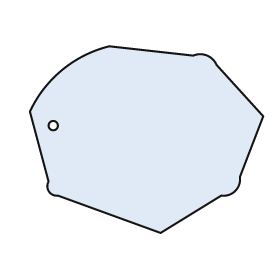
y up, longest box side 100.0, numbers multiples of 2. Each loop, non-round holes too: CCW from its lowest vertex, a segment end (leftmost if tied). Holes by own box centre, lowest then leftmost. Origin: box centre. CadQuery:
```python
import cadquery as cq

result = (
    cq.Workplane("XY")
    .moveTo(6.0, -40.0)
    .lineTo(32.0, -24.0)
    .threePointArc((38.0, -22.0), (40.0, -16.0))
    .lineTo(50.0, 10.0)
    .lineTo(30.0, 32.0)
    .threePointArc((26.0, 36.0), (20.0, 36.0))
    .lineTo(-16.0, 40.0)
    .threePointArc((-36.0, 30.0), (-50.0, 12.0))
    .lineTo(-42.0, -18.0)
    .threePointArc((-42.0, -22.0), (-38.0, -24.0))
    .close()
    .moveTo(-40.0, 6.0)
    .circle(2.0)
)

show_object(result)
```